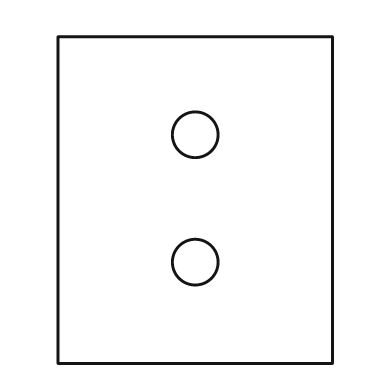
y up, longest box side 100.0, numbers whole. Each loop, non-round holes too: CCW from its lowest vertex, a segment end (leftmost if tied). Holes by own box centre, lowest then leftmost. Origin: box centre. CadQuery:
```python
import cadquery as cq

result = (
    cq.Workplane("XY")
    .moveTo(-42.0, -50.0)
    .lineTo(42.0, -50.0)
    .lineTo(42.0, 50.0)
    .lineTo(-42.0, 50.0)
    .close()
    .moveTo(0.0, -19.0)
    .circle(7.0)
    .moveTo(0.0, 20.0)
    .circle(7.0)
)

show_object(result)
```